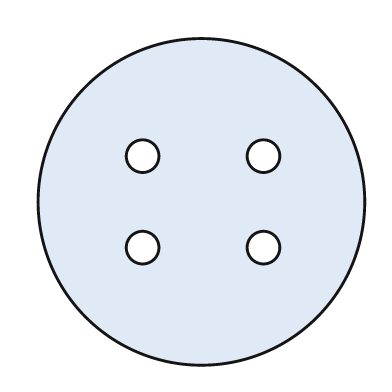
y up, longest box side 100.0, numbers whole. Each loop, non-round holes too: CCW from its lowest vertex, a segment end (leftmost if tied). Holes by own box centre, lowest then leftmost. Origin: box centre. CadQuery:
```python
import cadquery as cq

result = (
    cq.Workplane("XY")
    .moveTo(0.0, 0.0)
    .circle(50.0)
    .moveTo(-18.0, -14.0)
    .circle(5.0)
    .moveTo(19.0, -14.0)
    .circle(5.0)
    .moveTo(-18.0, 14.0)
    .circle(5.0)
    .moveTo(19.0, 14.0)
    .circle(5.0)
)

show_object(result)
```